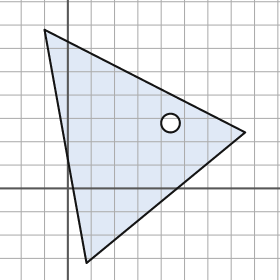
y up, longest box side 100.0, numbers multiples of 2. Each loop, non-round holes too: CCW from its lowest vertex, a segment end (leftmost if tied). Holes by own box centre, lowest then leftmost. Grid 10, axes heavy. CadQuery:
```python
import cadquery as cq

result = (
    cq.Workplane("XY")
    .moveTo(8.0, -32.0)
    .lineTo(76.0, 24.0)
    .lineTo(-10.0, 68.0)
    .close()
    .moveTo(44.0, 28.0)
    .circle(4.0)
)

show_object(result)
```